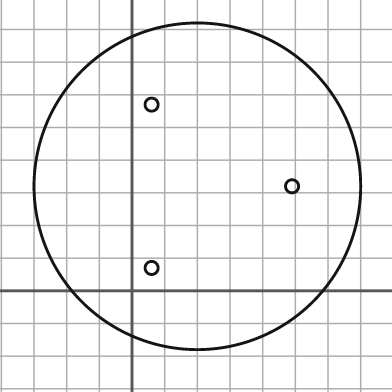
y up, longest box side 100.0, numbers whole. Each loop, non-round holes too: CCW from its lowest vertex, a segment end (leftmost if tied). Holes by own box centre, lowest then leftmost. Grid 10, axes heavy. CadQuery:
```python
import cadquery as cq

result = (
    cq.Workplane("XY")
    .moveTo(20.0, 32.0)
    .circle(50.0)
    .moveTo(6.0, 7.0)
    .circle(2.0)
    .moveTo(49.0, 32.0)
    .circle(2.0)
    .moveTo(6.0, 57.0)
    .circle(2.0)
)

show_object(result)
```